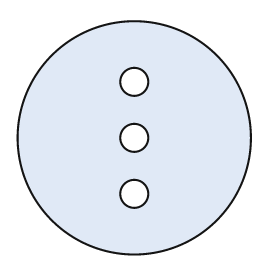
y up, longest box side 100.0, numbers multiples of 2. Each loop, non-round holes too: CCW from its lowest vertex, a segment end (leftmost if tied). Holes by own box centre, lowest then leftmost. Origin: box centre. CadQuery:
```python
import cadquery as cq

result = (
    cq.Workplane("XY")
    .moveTo(0.0, 0.0)
    .circle(50.0)
    .moveTo(0.0, -24.0)
    .circle(6.0)
    .moveTo(0.0, 0.0)
    .circle(6.0)
    .moveTo(0.0, 24.0)
    .circle(6.0)
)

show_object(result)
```